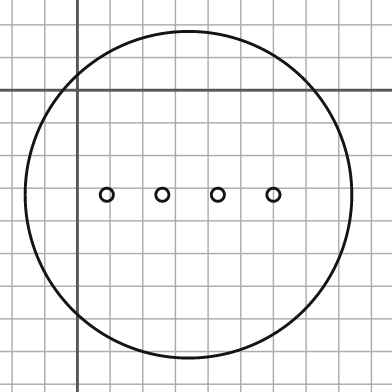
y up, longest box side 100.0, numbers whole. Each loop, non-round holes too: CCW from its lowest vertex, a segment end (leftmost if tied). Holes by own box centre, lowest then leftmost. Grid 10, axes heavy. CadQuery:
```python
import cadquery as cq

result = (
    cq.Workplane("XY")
    .moveTo(34.0, -32.0)
    .circle(50.0)
    .moveTo(9.0, -32.0)
    .circle(2.0)
    .moveTo(26.0, -32.0)
    .circle(2.0)
    .moveTo(43.0, -32.0)
    .circle(2.0)
    .moveTo(60.0, -32.0)
    .circle(2.0)
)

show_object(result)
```